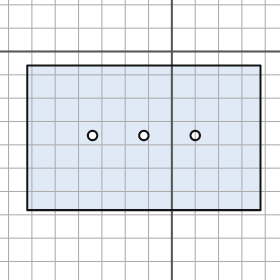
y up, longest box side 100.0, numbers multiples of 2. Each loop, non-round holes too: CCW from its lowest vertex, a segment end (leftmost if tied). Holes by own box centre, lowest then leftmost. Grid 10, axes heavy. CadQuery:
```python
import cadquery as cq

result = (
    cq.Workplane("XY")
    .moveTo(-62.0, -68.0)
    .lineTo(38.0, -68.0)
    .lineTo(38.0, -6.0)
    .lineTo(-62.0, -6.0)
    .close()
    .moveTo(-34.0, -36.0)
    .circle(2.0)
    .moveTo(-12.0, -36.0)
    .circle(2.0)
    .moveTo(10.0, -36.0)
    .circle(2.0)
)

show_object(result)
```